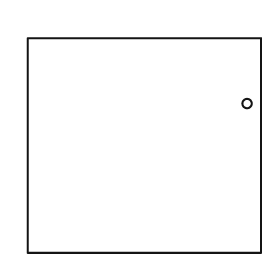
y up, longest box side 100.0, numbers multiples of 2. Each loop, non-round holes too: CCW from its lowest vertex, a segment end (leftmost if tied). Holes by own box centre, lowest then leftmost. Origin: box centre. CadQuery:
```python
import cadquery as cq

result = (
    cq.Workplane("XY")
    .moveTo(-50.0, -46.0)
    .lineTo(50.0, -46.0)
    .lineTo(50.0, 46.0)
    .lineTo(-50.0, 46.0)
    .close()
    .moveTo(44.0, 18.0)
    .circle(2.0)
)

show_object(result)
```